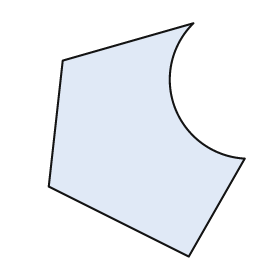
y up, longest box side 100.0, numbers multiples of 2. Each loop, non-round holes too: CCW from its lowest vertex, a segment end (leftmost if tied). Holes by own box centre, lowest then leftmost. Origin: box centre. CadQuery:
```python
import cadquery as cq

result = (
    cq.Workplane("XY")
    .moveTo(18.0, -50.0)
    .lineTo(42.0, -8.0)
    .threePointArc((12.0, 14.0), (20.0, 50.0))
    .lineTo(-36.0, 34.0)
    .lineTo(-42.0, -20.0)
    .close()
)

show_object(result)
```